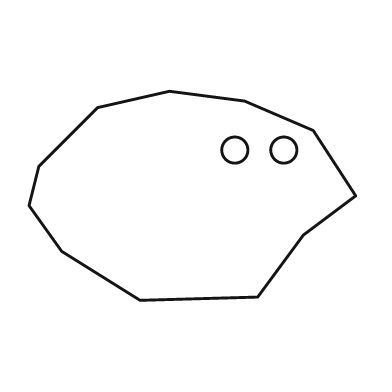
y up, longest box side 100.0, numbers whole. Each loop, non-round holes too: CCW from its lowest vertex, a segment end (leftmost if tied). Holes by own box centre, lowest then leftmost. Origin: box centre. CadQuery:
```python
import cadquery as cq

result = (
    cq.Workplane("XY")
    .moveTo(-16.0, -32.0)
    .lineTo(20.0, -31.0)
    .lineTo(34.0, -12.0)
    .lineTo(50.0, 0.0)
    .lineTo(37.0, 20.0)
    .lineTo(16.0, 29.0)
    .lineTo(-7.0, 32.0)
    .lineTo(-29.0, 27.0)
    .lineTo(-47.0, 9.0)
    .lineTo(-50.0, -3.0)
    .lineTo(-40.0, -17.0)
    .close()
    .moveTo(13.0, 14.0)
    .circle(4.0)
    .moveTo(28.0, 14.0)
    .circle(4.0)
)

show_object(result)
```